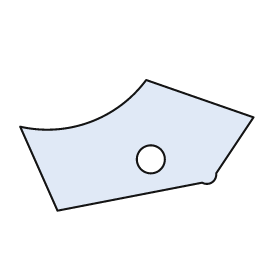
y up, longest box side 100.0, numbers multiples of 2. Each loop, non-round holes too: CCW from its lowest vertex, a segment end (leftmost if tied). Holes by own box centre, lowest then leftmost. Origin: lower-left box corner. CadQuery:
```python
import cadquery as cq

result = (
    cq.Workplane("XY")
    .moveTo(16.0, 0.0)
    .lineTo(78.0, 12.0)
    .threePointArc((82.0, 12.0), (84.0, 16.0))
    .lineTo(100.0, 40.0)
    .lineTo(54.0, 56.0)
    .threePointArc((30.0, 38.0), (0.0, 36.0))
    .close()
    .moveTo(56.0, 22.0)
    .circle(6.0)
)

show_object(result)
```